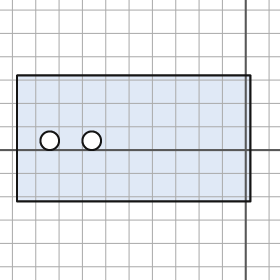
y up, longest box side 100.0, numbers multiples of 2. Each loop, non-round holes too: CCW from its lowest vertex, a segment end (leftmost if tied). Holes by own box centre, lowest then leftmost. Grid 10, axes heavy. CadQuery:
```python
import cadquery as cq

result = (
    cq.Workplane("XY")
    .moveTo(-98.0, -22.0)
    .lineTo(2.0, -22.0)
    .lineTo(2.0, 32.0)
    .lineTo(-98.0, 32.0)
    .close()
    .moveTo(-84.0, 4.0)
    .circle(4.0)
    .moveTo(-66.0, 4.0)
    .circle(4.0)
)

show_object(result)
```